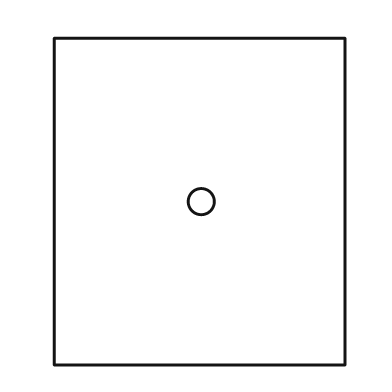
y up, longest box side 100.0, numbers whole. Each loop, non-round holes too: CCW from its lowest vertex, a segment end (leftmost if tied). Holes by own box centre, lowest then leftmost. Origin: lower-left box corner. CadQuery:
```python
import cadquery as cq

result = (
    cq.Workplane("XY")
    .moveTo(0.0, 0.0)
    .lineTo(89.0, 0.0)
    .lineTo(89.0, 100.0)
    .lineTo(0.0, 100.0)
    .close()
    .moveTo(45.0, 50.0)
    .circle(4.0)
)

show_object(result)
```